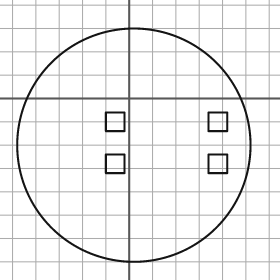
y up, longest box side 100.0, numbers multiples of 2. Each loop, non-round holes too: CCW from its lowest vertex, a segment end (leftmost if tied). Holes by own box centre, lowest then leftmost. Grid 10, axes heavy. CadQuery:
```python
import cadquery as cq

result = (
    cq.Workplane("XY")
    .moveTo(2.0, -20.0)
    .circle(50.0)
    .moveTo(-10.0, -32.0)
    .lineTo(-2.0, -32.0)
    .lineTo(-2.0, -24.0)
    .lineTo(-10.0, -24.0)
    .close()
    .moveTo(34.0, -32.0)
    .lineTo(42.0, -32.0)
    .lineTo(42.0, -24.0)
    .lineTo(34.0, -24.0)
    .close()
    .moveTo(-10.0, -14.0)
    .lineTo(-2.0, -14.0)
    .lineTo(-2.0, -6.0)
    .lineTo(-10.0, -6.0)
    .close()
    .moveTo(34.0, -14.0)
    .lineTo(42.0, -14.0)
    .lineTo(42.0, -6.0)
    .lineTo(34.0, -6.0)
    .close()
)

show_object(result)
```